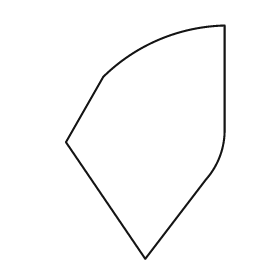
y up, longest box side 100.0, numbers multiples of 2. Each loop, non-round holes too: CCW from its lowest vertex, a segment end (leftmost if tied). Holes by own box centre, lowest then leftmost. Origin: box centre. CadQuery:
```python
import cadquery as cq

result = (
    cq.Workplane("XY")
    .moveTo(0.0, -50.0)
    .lineTo(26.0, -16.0)
    .threePointArc((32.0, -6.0), (34.0, 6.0))
    .lineTo(34.0, 50.0)
    .threePointArc((6.0, 44.0), (-18.0, 28.0))
    .lineTo(-34.0, 0.0)
    .close()
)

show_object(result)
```